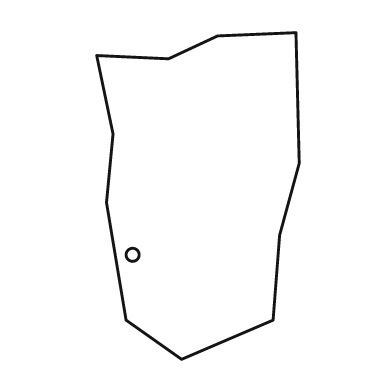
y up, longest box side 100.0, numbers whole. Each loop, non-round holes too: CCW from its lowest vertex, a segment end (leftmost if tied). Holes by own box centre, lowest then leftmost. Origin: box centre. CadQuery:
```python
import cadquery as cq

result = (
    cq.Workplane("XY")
    .moveTo(-5.0, -50.0)
    .lineTo(23.0, -38.0)
    .lineTo(25.0, -12.0)
    .lineTo(31.0, 10.0)
    .lineTo(30.0, 50.0)
    .lineTo(6.0, 49.0)
    .lineTo(-9.0, 42.0)
    .lineTo(-31.0, 43.0)
    .lineTo(-26.0, 19.0)
    .lineTo(-28.0, -2.0)
    .lineTo(-22.0, -38.0)
    .close()
    .moveTo(-20.0, -18.0)
    .circle(2.0)
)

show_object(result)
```